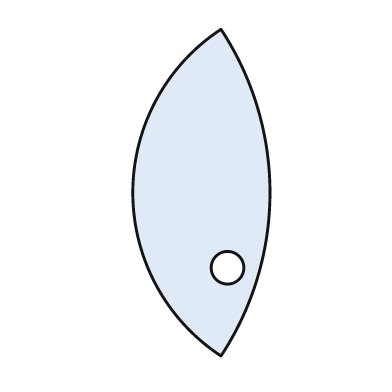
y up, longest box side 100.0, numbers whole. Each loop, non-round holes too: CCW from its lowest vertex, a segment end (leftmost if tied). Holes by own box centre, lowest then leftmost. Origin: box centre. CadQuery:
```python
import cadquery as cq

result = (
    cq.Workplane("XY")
    .moveTo(6.0, -50.0)
    .threePointArc((21.0, 0.0), (6.0, 50.0))
    .threePointArc((-21.0, 0.0), (6.0, -50.0))
    .close()
    .moveTo(8.0, -23.0)
    .circle(5.0)
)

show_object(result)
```